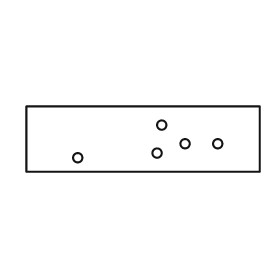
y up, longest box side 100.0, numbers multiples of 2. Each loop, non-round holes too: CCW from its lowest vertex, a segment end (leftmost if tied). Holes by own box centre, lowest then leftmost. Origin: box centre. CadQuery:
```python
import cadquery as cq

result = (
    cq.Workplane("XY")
    .moveTo(-50.0, -14.0)
    .lineTo(50.0, -14.0)
    .lineTo(50.0, 14.0)
    .lineTo(-50.0, 14.0)
    .close()
    .moveTo(-28.0, -8.0)
    .circle(2.0)
    .moveTo(6.0, -6.0)
    .circle(2.0)
    .moveTo(18.0, -2.0)
    .circle(2.0)
    .moveTo(32.0, -2.0)
    .circle(2.0)
    .moveTo(8.0, 6.0)
    .circle(2.0)
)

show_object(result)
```